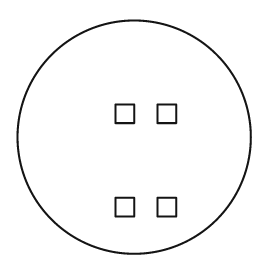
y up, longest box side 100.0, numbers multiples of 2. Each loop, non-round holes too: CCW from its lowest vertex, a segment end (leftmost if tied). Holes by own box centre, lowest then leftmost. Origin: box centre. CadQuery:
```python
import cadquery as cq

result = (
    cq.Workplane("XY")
    .moveTo(0.0, 0.0)
    .circle(50.0)
    .moveTo(-8.0, -34.0)
    .lineTo(0.0, -34.0)
    .lineTo(0.0, -26.0)
    .lineTo(-8.0, -26.0)
    .close()
    .moveTo(10.0, -34.0)
    .lineTo(18.0, -34.0)
    .lineTo(18.0, -26.0)
    .lineTo(10.0, -26.0)
    .close()
    .moveTo(-8.0, 6.0)
    .lineTo(0.0, 6.0)
    .lineTo(0.0, 14.0)
    .lineTo(-8.0, 14.0)
    .close()
    .moveTo(10.0, 6.0)
    .lineTo(18.0, 6.0)
    .lineTo(18.0, 14.0)
    .lineTo(10.0, 14.0)
    .close()
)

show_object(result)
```